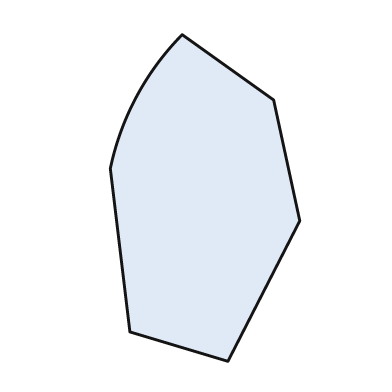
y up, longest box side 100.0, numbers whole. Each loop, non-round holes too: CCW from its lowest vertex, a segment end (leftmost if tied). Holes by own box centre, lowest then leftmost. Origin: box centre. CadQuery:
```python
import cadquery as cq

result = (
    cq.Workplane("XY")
    .moveTo(7.0, -50.0)
    .lineTo(29.0, -7.0)
    .lineTo(21.0, 30.0)
    .lineTo(-7.0, 50.0)
    .threePointArc((-21.0, 31.0), (-29.0, 9.0))
    .lineTo(-23.0, -41.0)
    .close()
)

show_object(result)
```